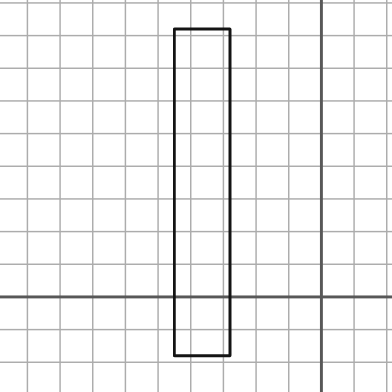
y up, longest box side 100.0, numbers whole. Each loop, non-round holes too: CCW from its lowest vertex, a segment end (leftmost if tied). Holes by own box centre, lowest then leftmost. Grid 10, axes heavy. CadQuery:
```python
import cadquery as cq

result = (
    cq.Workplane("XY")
    .moveTo(-45.0, -18.0)
    .lineTo(-28.0, -18.0)
    .lineTo(-28.0, 82.0)
    .lineTo(-45.0, 82.0)
    .close()
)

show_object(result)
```